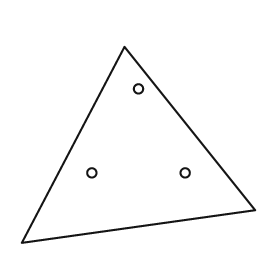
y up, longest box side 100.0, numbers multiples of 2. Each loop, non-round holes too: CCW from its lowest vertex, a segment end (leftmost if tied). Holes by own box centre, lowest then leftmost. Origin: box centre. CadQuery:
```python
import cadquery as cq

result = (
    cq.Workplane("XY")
    .moveTo(-50.0, -42.0)
    .lineTo(50.0, -28.0)
    .lineTo(-6.0, 42.0)
    .close()
    .moveTo(-20.0, -12.0)
    .circle(2.0)
    .moveTo(20.0, -12.0)
    .circle(2.0)
    .moveTo(0.0, 24.0)
    .circle(2.0)
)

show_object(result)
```